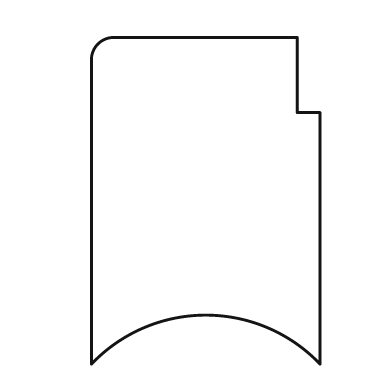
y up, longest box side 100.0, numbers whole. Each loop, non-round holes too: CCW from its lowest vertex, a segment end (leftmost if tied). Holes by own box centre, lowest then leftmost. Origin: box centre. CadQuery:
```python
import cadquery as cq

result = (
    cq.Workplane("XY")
    .moveTo(-35.0, -50.0)
    .threePointArc((0.0, -35.0), (35.0, -50.0))
    .lineTo(35.0, 27.0)
    .lineTo(28.0, 27.0)
    .lineTo(28.0, 50.0)
    .lineTo(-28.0, 50.0)
    .threePointArc((-33.0, 48.0), (-35.0, 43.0))
    .close()
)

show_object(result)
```